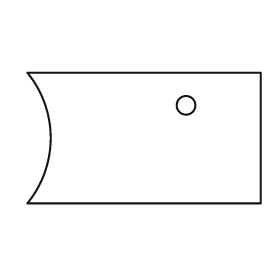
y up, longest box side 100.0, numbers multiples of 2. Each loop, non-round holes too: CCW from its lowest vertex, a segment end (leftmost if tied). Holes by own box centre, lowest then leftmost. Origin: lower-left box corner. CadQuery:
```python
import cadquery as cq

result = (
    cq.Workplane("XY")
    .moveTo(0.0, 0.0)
    .lineTo(100.0, 0.0)
    .lineTo(100.0, 56.0)
    .lineTo(0.0, 56.0)
    .threePointArc((10.0, 28.0), (0.0, 0.0))
    .close()
    .moveTo(68.0, 42.0)
    .circle(4.0)
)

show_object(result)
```